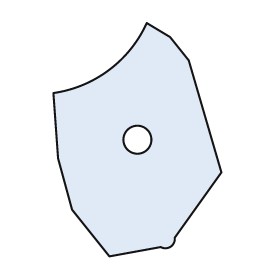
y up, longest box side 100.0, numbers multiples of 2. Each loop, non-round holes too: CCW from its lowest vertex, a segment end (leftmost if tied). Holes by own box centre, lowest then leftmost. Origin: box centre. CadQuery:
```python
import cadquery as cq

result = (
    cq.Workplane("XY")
    .moveTo(-12.0, -50.0)
    .lineTo(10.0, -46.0)
    .threePointArc((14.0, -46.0), (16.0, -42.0))
    .lineTo(36.0, -14.0)
    .lineTo(22.0, 34.0)
    .lineTo(14.0, 44.0)
    .lineTo(4.0, 50.0)
    .threePointArc((-12.0, 30.0), (-36.0, 20.0))
    .lineTo(-34.0, -8.0)
    .lineTo(-28.0, -30.0)
    .close()
    .moveTo(0.0, 0.0)
    .circle(6.0)
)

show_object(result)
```